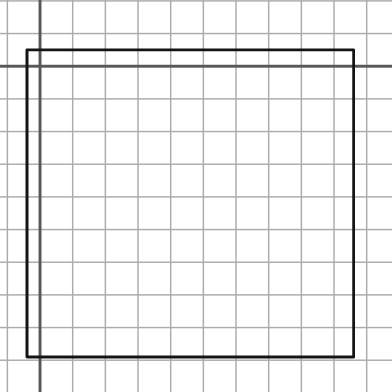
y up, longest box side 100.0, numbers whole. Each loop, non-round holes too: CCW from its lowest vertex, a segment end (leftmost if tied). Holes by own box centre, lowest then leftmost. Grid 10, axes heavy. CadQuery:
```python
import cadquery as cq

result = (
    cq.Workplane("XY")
    .moveTo(-4.0, -89.0)
    .lineTo(96.0, -89.0)
    .lineTo(96.0, 5.0)
    .lineTo(-4.0, 5.0)
    .close()
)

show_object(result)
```